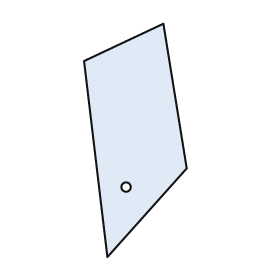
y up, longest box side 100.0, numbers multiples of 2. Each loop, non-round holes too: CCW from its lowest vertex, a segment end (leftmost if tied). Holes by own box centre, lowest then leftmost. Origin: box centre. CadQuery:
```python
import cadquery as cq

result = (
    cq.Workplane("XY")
    .moveTo(-12.0, -50.0)
    .lineTo(22.0, -12.0)
    .lineTo(12.0, 50.0)
    .lineTo(-22.0, 34.0)
    .close()
    .moveTo(-4.0, -20.0)
    .circle(2.0)
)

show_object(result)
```